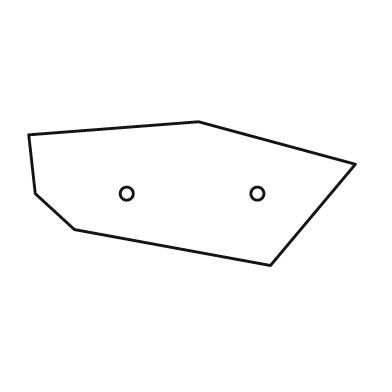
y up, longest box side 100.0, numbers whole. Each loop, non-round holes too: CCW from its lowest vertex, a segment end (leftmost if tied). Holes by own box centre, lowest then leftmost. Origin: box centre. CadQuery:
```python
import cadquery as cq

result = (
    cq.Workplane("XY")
    .moveTo(24.0, -22.0)
    .lineTo(50.0, 9.0)
    .lineTo(2.0, 22.0)
    .lineTo(-50.0, 18.0)
    .lineTo(-48.0, 0.0)
    .lineTo(-36.0, -11.0)
    .close()
    .moveTo(-20.0, 0.0)
    .circle(2.0)
    .moveTo(20.0, 0.0)
    .circle(2.0)
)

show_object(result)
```